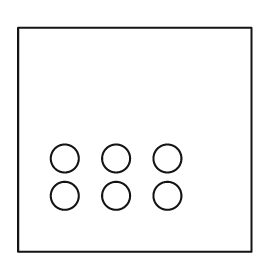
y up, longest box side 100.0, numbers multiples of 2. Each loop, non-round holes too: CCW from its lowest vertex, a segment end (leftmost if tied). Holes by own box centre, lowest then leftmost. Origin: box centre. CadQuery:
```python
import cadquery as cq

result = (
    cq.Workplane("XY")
    .moveTo(-50.0, -48.0)
    .lineTo(50.0, -48.0)
    .lineTo(50.0, 48.0)
    .lineTo(-50.0, 48.0)
    .close()
    .moveTo(-30.0, -24.0)
    .circle(6.0)
    .moveTo(-8.0, -24.0)
    .circle(6.0)
    .moveTo(14.0, -24.0)
    .circle(6.0)
    .moveTo(-30.0, -8.0)
    .circle(6.0)
    .moveTo(-8.0, -8.0)
    .circle(6.0)
    .moveTo(14.0, -8.0)
    .circle(6.0)
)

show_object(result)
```